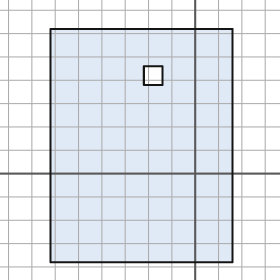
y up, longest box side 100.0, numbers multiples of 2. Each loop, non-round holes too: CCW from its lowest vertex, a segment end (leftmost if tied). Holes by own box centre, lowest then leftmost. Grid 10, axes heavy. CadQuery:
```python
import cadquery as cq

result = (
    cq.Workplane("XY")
    .moveTo(-62.0, -38.0)
    .lineTo(16.0, -38.0)
    .lineTo(16.0, 62.0)
    .lineTo(-62.0, 62.0)
    .close()
    .moveTo(-22.0, 38.0)
    .lineTo(-14.0, 38.0)
    .lineTo(-14.0, 46.0)
    .lineTo(-22.0, 46.0)
    .close()
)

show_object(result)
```